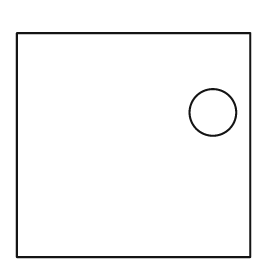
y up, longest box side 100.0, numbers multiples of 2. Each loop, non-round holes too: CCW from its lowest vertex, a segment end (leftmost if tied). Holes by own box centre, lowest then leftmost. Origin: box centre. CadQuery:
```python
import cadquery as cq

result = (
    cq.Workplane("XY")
    .moveTo(-50.0, -48.0)
    .lineTo(50.0, -48.0)
    .lineTo(50.0, 48.0)
    .lineTo(-50.0, 48.0)
    .close()
    .moveTo(34.0, 14.0)
    .circle(10.0)
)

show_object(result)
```